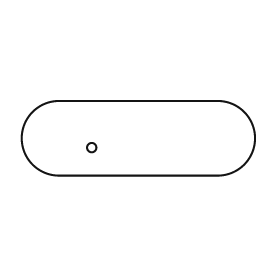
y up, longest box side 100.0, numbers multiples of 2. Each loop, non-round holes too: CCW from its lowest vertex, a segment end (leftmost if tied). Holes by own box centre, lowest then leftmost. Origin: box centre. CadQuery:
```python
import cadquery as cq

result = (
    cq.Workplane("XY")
    .moveTo(-34.0, -16.0)
    .lineTo(34.0, -16.0)
    .threePointArc((50.0, 0.0), (34.0, 16.0))
    .lineTo(-34.0, 16.0)
    .threePointArc((-50.0, 0.0), (-34.0, -16.0))
    .close()
    .moveTo(-20.0, -4.0)
    .circle(2.0)
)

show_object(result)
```